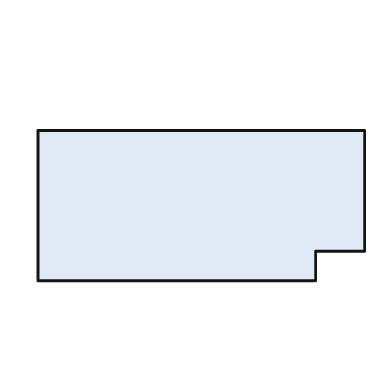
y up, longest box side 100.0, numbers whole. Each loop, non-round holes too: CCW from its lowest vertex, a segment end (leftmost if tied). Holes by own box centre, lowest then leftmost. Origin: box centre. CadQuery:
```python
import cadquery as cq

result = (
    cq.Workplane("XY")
    .moveTo(-50.0, -23.0)
    .lineTo(35.0, -23.0)
    .lineTo(35.0, -14.0)
    .lineTo(50.0, -14.0)
    .lineTo(50.0, 23.0)
    .lineTo(-50.0, 23.0)
    .close()
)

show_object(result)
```